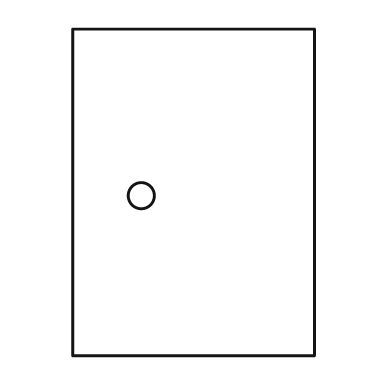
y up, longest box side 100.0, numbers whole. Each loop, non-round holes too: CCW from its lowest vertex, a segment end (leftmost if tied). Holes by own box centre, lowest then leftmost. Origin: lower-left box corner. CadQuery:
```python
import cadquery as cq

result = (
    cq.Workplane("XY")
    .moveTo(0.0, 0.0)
    .lineTo(74.0, 0.0)
    .lineTo(74.0, 100.0)
    .lineTo(0.0, 100.0)
    .close()
    .moveTo(21.0, 49.0)
    .circle(4.0)
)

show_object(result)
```